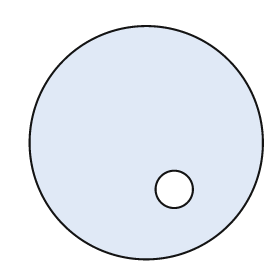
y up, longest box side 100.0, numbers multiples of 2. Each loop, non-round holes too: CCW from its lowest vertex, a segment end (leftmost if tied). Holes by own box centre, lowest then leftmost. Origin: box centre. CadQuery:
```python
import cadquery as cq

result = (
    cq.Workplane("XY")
    .moveTo(0.0, 0.0)
    .circle(50.0)
    .moveTo(12.0, -20.0)
    .circle(8.0)
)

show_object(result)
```